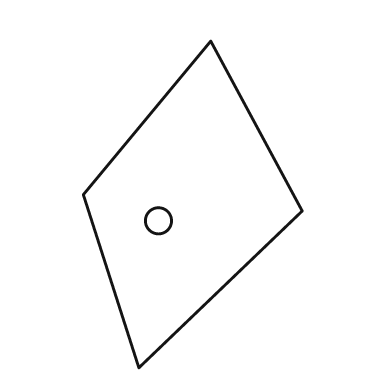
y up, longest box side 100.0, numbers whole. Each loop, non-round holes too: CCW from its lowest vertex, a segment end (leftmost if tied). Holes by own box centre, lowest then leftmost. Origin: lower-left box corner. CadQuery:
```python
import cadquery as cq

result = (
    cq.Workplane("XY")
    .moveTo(17.0, 0.0)
    .lineTo(67.0, 48.0)
    .lineTo(39.0, 100.0)
    .lineTo(0.0, 53.0)
    .close()
    .moveTo(23.0, 45.0)
    .circle(4.0)
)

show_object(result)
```